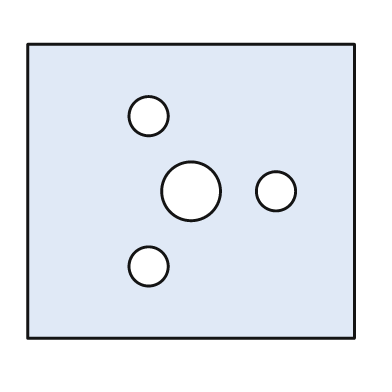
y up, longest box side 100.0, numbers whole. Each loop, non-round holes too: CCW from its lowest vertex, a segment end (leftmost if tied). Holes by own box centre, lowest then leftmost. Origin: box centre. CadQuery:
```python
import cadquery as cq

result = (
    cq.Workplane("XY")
    .moveTo(-50.0, -45.0)
    .lineTo(50.0, -45.0)
    .lineTo(50.0, 45.0)
    .lineTo(-50.0, 45.0)
    .close()
    .moveTo(-13.0, -23.0)
    .circle(6.0)
    .moveTo(0.0, 0.0)
    .circle(9.0)
    .moveTo(26.0, 0.0)
    .circle(6.0)
    .moveTo(-13.0, 23.0)
    .circle(6.0)
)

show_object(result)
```